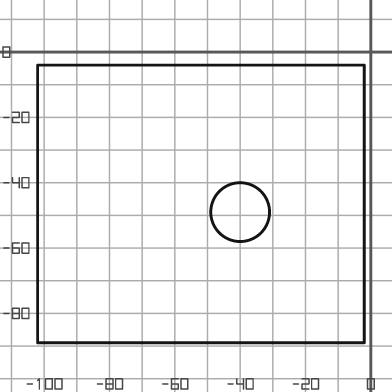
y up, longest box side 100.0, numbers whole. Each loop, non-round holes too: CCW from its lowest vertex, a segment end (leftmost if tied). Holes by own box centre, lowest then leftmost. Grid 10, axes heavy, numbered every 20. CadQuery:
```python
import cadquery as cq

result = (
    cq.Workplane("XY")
    .moveTo(-102.0, -89.0)
    .lineTo(-2.0, -89.0)
    .lineTo(-2.0, -4.0)
    .lineTo(-102.0, -4.0)
    .close()
    .moveTo(-40.0, -49.0)
    .circle(9.0)
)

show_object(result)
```